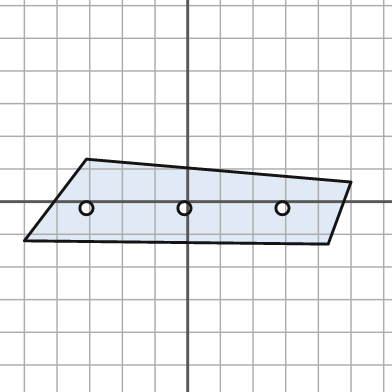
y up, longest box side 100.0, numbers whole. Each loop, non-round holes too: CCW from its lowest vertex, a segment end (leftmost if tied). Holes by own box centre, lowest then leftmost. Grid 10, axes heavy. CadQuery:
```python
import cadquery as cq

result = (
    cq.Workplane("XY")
    .moveTo(43.0, -13.0)
    .lineTo(50.0, 6.0)
    .lineTo(-31.0, 13.0)
    .lineTo(-50.0, -12.0)
    .close()
    .moveTo(-31.0, -2.0)
    .circle(2.0)
    .moveTo(-1.0, -2.0)
    .circle(2.0)
    .moveTo(29.0, -2.0)
    .circle(2.0)
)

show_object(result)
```